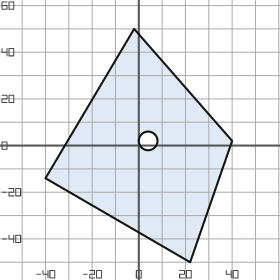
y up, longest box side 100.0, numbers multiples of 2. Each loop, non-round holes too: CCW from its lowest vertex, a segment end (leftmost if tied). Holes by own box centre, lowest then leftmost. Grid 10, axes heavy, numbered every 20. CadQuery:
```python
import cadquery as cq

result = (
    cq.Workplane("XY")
    .moveTo(22.0, -50.0)
    .lineTo(40.0, 2.0)
    .lineTo(-2.0, 50.0)
    .lineTo(-40.0, -14.0)
    .close()
    .moveTo(4.0, 2.0)
    .circle(4.0)
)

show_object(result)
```